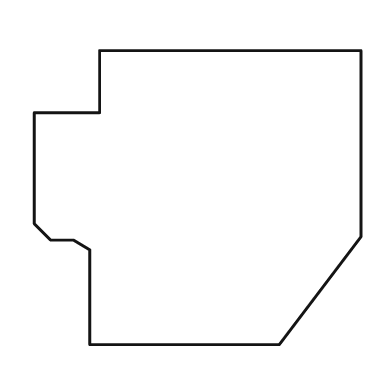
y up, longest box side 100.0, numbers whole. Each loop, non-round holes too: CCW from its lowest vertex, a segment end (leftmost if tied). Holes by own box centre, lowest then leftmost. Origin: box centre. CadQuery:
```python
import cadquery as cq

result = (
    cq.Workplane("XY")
    .moveTo(-33.0, -45.0)
    .lineTo(25.0, -45.0)
    .lineTo(50.0, -12.0)
    .lineTo(50.0, 45.0)
    .lineTo(-30.0, 45.0)
    .lineTo(-30.0, 26.0)
    .lineTo(-50.0, 26.0)
    .lineTo(-50.0, -8.0)
    .lineTo(-45.0, -13.0)
    .lineTo(-38.0, -13.0)
    .lineTo(-33.0, -16.0)
    .close()
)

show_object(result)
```